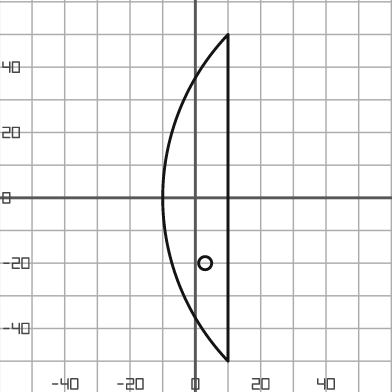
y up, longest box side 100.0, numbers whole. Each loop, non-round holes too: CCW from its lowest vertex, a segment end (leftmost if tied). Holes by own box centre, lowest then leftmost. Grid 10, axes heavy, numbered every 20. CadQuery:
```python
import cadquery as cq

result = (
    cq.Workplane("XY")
    .moveTo(10.0, -50.0)
    .lineTo(10.0, 50.0)
    .threePointArc((-10.0, 0.0), (10.0, -50.0))
    .close()
    .moveTo(3.0, -20.0)
    .circle(2.0)
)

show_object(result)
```